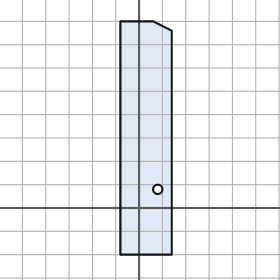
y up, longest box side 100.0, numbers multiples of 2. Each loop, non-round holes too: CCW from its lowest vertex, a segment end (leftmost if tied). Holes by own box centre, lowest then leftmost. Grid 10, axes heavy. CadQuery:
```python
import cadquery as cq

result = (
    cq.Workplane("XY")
    .moveTo(-8.0, -20.0)
    .lineTo(14.0, -20.0)
    .lineTo(14.0, 76.0)
    .lineTo(6.0, 80.0)
    .lineTo(-8.0, 80.0)
    .close()
    .moveTo(8.0, 8.0)
    .circle(2.0)
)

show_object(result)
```